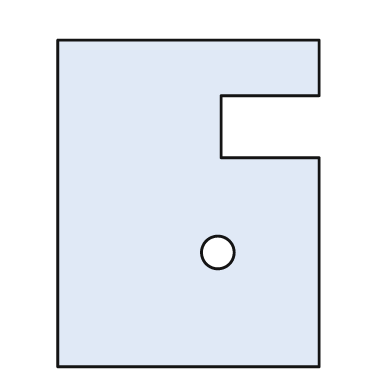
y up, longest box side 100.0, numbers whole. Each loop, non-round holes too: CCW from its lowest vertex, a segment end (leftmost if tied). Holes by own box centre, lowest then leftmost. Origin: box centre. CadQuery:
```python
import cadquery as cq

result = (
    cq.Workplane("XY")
    .moveTo(-40.0, -50.0)
    .lineTo(40.0, -50.0)
    .lineTo(40.0, 14.0)
    .lineTo(10.0, 14.0)
    .lineTo(10.0, 33.0)
    .lineTo(40.0, 33.0)
    .lineTo(40.0, 50.0)
    .lineTo(-40.0, 50.0)
    .close()
    .moveTo(9.0, -15.0)
    .circle(5.0)
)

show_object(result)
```